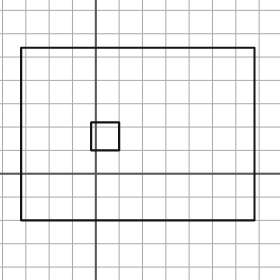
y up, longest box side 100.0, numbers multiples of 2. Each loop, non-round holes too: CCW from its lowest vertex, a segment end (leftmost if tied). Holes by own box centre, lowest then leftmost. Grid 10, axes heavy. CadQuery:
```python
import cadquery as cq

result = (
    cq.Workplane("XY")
    .moveTo(-32.0, -20.0)
    .lineTo(68.0, -20.0)
    .lineTo(68.0, 54.0)
    .lineTo(-32.0, 54.0)
    .close()
    .moveTo(-2.0, 10.0)
    .lineTo(10.0, 10.0)
    .lineTo(10.0, 22.0)
    .lineTo(-2.0, 22.0)
    .close()
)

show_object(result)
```